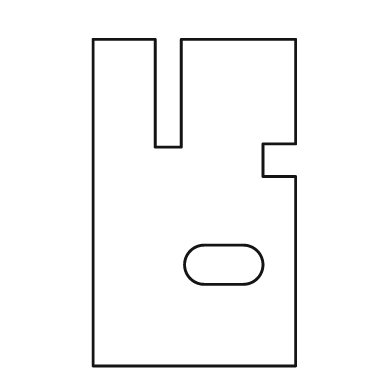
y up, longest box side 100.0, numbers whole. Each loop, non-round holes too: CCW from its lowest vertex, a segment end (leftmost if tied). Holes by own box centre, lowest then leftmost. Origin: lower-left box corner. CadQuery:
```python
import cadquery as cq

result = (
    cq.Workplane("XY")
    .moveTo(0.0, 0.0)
    .lineTo(62.0, 0.0)
    .lineTo(62.0, 58.0)
    .lineTo(52.0, 58.0)
    .lineTo(52.0, 68.0)
    .lineTo(62.0, 68.0)
    .lineTo(62.0, 100.0)
    .lineTo(27.0, 100.0)
    .lineTo(27.0, 67.0)
    .lineTo(19.0, 67.0)
    .lineTo(19.0, 100.0)
    .lineTo(0.0, 100.0)
    .close()
    .moveTo(34.0, 25.0)
    .lineTo(46.0, 25.0)
    .threePointArc((52.0, 31.0), (46.0, 37.0))
    .lineTo(34.0, 37.0)
    .threePointArc((28.0, 31.0), (34.0, 25.0))
    .close()
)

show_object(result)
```